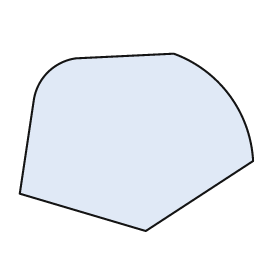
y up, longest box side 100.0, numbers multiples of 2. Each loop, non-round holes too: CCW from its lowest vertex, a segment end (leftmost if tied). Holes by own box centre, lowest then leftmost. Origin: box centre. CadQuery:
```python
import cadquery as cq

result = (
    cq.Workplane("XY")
    .moveTo(4.0, -38.0)
    .lineTo(50.0, -8.0)
    .threePointArc((40.0, 20.0), (16.0, 38.0))
    .lineTo(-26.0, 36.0)
    .threePointArc((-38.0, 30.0), (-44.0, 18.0))
    .lineTo(-50.0, -22.0)
    .close()
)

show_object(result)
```